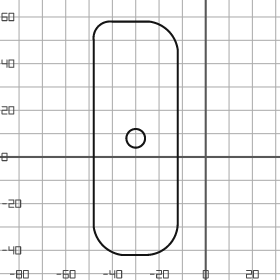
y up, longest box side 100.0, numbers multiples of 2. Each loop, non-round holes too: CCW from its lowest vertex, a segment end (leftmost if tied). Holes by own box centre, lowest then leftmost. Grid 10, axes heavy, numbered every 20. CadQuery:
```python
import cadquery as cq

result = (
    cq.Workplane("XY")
    .moveTo(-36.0, -42.0)
    .lineTo(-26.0, -42.0)
    .threePointArc((-16.0, -38.0), (-12.0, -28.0))
    .lineTo(-12.0, 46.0)
    .threePointArc((-16.0, 54.0), (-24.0, 58.0))
    .lineTo(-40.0, 58.0)
    .threePointArc((-46.0, 56.0), (-48.0, 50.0))
    .lineTo(-48.0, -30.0)
    .threePointArc((-44.0, -38.0), (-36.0, -42.0))
    .close()
    .moveTo(-30.0, 8.0)
    .circle(4.0)
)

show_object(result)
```